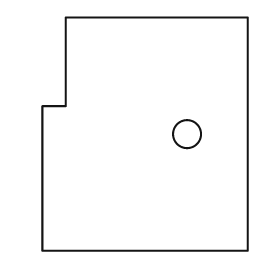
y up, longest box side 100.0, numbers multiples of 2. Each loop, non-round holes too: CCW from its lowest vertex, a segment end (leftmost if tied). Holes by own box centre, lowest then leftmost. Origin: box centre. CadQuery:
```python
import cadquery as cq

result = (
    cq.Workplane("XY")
    .moveTo(-44.0, -50.0)
    .lineTo(44.0, -50.0)
    .lineTo(44.0, 50.0)
    .lineTo(-34.0, 50.0)
    .lineTo(-34.0, 12.0)
    .lineTo(-44.0, 12.0)
    .close()
    .moveTo(18.0, 0.0)
    .circle(6.0)
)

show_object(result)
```